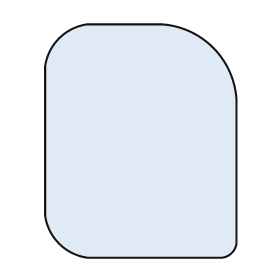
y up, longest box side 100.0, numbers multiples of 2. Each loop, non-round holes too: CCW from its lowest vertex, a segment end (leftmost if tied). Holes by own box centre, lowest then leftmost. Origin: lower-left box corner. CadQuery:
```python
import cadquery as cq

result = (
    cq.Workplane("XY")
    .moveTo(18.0, 0.0)
    .lineTo(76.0, 0.0)
    .threePointArc((80.0, 2.0), (82.0, 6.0))
    .lineTo(82.0, 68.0)
    .threePointArc((72.0, 90.0), (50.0, 100.0))
    .lineTo(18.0, 100.0)
    .threePointArc((6.0, 94.0), (0.0, 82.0))
    .lineTo(0.0, 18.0)
    .threePointArc((6.0, 6.0), (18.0, 0.0))
    .close()
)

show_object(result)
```